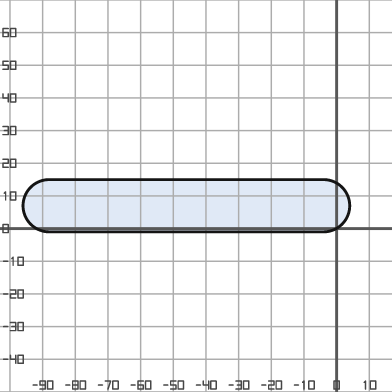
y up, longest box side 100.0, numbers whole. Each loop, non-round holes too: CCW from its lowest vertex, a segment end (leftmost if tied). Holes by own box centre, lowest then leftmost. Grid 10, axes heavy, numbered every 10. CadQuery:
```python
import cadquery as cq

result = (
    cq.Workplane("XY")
    .moveTo(-88.0, -1.0)
    .lineTo(-4.0, -1.0)
    .threePointArc((4.0, 7.0), (-4.0, 15.0))
    .lineTo(-88.0, 15.0)
    .threePointArc((-96.0, 7.0), (-88.0, -1.0))
    .close()
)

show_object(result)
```